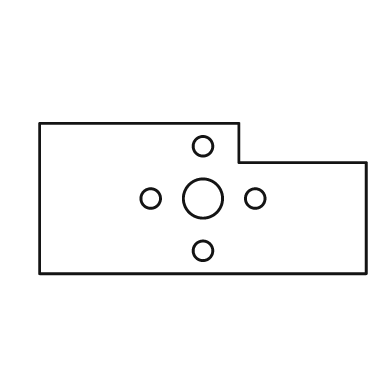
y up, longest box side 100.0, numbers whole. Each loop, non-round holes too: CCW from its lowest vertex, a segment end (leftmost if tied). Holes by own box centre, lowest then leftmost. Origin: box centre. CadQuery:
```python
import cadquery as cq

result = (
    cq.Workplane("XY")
    .moveTo(-50.0, -23.0)
    .lineTo(50.0, -23.0)
    .lineTo(50.0, 11.0)
    .lineTo(11.0, 11.0)
    .lineTo(11.0, 23.0)
    .lineTo(-50.0, 23.0)
    .close()
    .moveTo(0.0, -16.0)
    .circle(3.0)
    .moveTo(-16.0, 0.0)
    .circle(3.0)
    .moveTo(0.0, 0.0)
    .circle(6.0)
    .moveTo(16.0, 0.0)
    .circle(3.0)
    .moveTo(0.0, 16.0)
    .circle(3.0)
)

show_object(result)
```